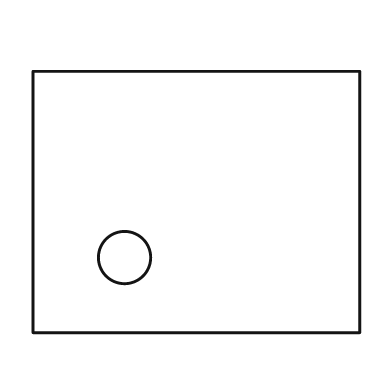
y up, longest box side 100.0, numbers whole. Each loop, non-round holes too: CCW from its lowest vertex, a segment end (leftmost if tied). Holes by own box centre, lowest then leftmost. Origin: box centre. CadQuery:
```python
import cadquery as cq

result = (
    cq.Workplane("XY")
    .moveTo(-50.0, -40.0)
    .lineTo(50.0, -40.0)
    .lineTo(50.0, 40.0)
    .lineTo(-50.0, 40.0)
    .close()
    .moveTo(-22.0, -17.0)
    .circle(8.0)
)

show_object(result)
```